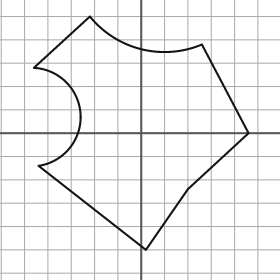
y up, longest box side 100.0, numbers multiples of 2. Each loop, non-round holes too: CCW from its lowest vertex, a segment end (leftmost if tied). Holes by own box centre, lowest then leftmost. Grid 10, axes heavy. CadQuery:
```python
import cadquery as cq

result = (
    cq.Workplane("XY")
    .moveTo(2.0, -50.0)
    .lineTo(20.0, -24.0)
    .lineTo(46.0, 0.0)
    .lineTo(26.0, 38.0)
    .threePointArc((0.0, 36.0), (-22.0, 50.0))
    .lineTo(-46.0, 28.0)
    .threePointArc((-26.0, 8.0), (-44.0, -14.0))
    .close()
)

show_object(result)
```